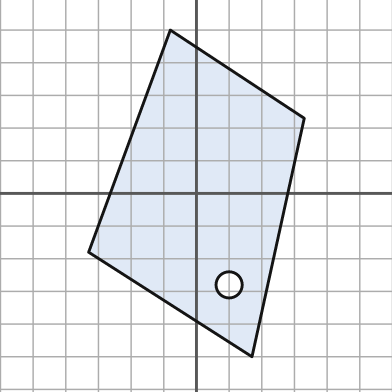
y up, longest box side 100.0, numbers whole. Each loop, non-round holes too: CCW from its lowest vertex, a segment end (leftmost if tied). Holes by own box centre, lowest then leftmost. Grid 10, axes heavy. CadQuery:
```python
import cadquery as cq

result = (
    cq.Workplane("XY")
    .moveTo(17.0, -50.0)
    .lineTo(33.0, 23.0)
    .lineTo(-8.0, 50.0)
    .lineTo(-33.0, -18.0)
    .close()
    .moveTo(10.0, -28.0)
    .circle(4.0)
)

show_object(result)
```